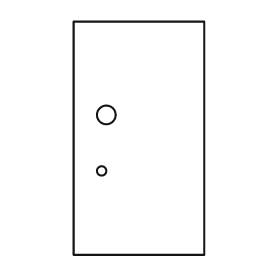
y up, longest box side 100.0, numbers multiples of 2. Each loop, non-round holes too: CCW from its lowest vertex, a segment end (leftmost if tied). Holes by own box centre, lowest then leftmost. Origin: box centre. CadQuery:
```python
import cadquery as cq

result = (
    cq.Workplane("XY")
    .moveTo(-28.0, -50.0)
    .lineTo(28.0, -50.0)
    .lineTo(28.0, 50.0)
    .lineTo(-28.0, 50.0)
    .close()
    .moveTo(-16.0, -14.0)
    .circle(2.0)
    .moveTo(-14.0, 10.0)
    .circle(4.0)
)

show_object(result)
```